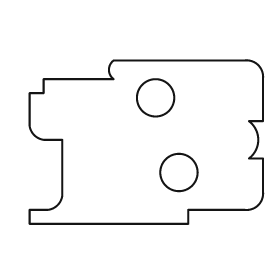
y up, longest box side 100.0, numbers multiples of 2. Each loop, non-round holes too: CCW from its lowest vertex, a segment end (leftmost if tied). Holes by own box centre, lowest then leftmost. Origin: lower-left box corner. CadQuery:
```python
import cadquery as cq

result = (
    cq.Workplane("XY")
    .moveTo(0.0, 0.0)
    .lineTo(68.0, 0.0)
    .lineTo(68.0, 6.0)
    .lineTo(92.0, 6.0)
    .threePointArc((98.0, 8.0), (100.0, 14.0))
    .lineTo(100.0, 28.0)
    .lineTo(94.0, 28.0)
    .threePointArc((98.0, 36.0), (94.0, 44.0))
    .lineTo(100.0, 44.0)
    .lineTo(100.0, 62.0)
    .threePointArc((98.0, 68.0), (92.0, 70.0))
    .lineTo(36.0, 70.0)
    .threePointArc((34.0, 66.0), (36.0, 62.0))
    .lineTo(6.0, 62.0)
    .lineTo(6.0, 56.0)
    .lineTo(0.0, 56.0)
    .lineTo(0.0, 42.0)
    .threePointArc((2.0, 38.0), (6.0, 36.0))
    .lineTo(14.0, 36.0)
    .lineTo(14.0, 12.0)
    .threePointArc((12.0, 8.0), (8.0, 6.0))
    .lineTo(0.0, 6.0)
    .close()
    .moveTo(64.0, 22.0)
    .circle(8.0)
    .moveTo(54.0, 54.0)
    .circle(8.0)
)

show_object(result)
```